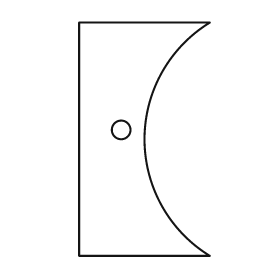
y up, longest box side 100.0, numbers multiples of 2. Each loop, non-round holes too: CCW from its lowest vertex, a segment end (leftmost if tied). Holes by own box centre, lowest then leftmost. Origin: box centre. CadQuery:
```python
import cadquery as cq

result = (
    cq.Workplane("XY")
    .moveTo(-28.0, -50.0)
    .lineTo(28.0, -50.0)
    .threePointArc((0.0, 0.0), (28.0, 50.0))
    .lineTo(-28.0, 50.0)
    .close()
    .moveTo(-10.0, 4.0)
    .circle(4.0)
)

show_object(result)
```